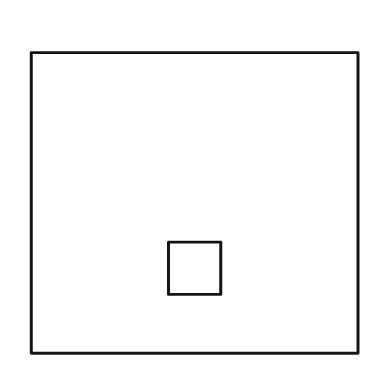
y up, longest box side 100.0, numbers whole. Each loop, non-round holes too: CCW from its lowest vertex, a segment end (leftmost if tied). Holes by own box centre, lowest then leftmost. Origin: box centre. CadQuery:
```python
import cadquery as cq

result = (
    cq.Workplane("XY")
    .moveTo(-50.0, -46.0)
    .lineTo(50.0, -46.0)
    .lineTo(50.0, 46.0)
    .lineTo(-50.0, 46.0)
    .close()
    .moveTo(-8.0, -28.0)
    .lineTo(8.0, -28.0)
    .lineTo(8.0, -12.0)
    .lineTo(-8.0, -12.0)
    .close()
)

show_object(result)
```